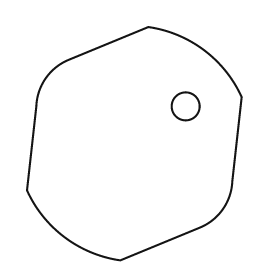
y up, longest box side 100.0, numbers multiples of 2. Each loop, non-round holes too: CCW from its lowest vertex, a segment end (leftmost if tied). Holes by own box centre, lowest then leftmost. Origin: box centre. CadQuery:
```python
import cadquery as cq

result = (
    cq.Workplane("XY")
    .moveTo(-6.0, -50.0)
    .lineTo(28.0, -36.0)
    .threePointArc((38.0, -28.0), (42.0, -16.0))
    .lineTo(46.0, 20.0)
    .threePointArc((30.0, 40.0), (6.0, 50.0))
    .lineTo(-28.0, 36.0)
    .threePointArc((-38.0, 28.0), (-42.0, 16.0))
    .lineTo(-46.0, -20.0)
    .threePointArc((-30.0, -40.0), (-6.0, -50.0))
    .close()
    .moveTo(22.0, 16.0)
    .circle(6.0)
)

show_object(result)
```